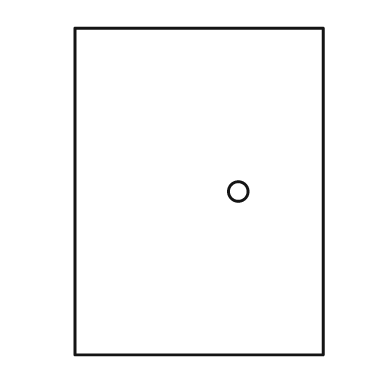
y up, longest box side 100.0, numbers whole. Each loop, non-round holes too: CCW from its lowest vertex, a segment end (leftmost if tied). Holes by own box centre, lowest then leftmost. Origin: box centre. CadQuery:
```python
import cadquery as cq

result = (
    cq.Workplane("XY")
    .moveTo(-38.0, -50.0)
    .lineTo(38.0, -50.0)
    .lineTo(38.0, 50.0)
    .lineTo(-38.0, 50.0)
    .close()
    .moveTo(12.0, 0.0)
    .circle(3.0)
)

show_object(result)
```